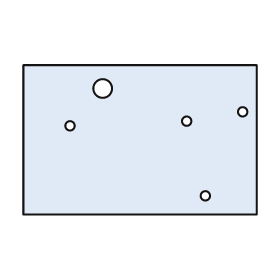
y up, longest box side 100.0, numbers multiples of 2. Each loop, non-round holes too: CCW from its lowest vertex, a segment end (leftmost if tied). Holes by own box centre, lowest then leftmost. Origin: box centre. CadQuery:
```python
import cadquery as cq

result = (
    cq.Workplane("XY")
    .moveTo(-50.0, -32.0)
    .lineTo(50.0, -32.0)
    .lineTo(50.0, 32.0)
    .lineTo(-50.0, 32.0)
    .close()
    .moveTo(28.0, -24.0)
    .circle(2.0)
    .moveTo(-30.0, 6.0)
    .circle(2.0)
    .moveTo(20.0, 8.0)
    .circle(2.0)
    .moveTo(44.0, 12.0)
    .circle(2.0)
    .moveTo(-16.0, 22.0)
    .circle(4.0)
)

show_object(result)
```